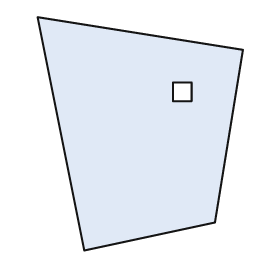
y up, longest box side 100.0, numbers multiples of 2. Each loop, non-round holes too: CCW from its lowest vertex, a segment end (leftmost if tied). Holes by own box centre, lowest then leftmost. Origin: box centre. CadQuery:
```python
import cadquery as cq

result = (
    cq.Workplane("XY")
    .moveTo(-24.0, -50.0)
    .lineTo(32.0, -38.0)
    .lineTo(44.0, 36.0)
    .lineTo(-44.0, 50.0)
    .close()
    .moveTo(14.0, 14.0)
    .lineTo(22.0, 14.0)
    .lineTo(22.0, 22.0)
    .lineTo(14.0, 22.0)
    .close()
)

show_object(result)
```